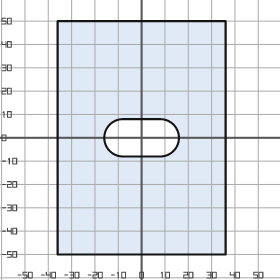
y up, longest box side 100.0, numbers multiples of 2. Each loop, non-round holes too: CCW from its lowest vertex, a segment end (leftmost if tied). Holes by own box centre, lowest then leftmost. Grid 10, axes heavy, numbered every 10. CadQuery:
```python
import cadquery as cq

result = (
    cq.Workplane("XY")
    .moveTo(-36.0, -50.0)
    .lineTo(36.0, -50.0)
    .lineTo(36.0, 50.0)
    .lineTo(-36.0, 50.0)
    .close()
    .moveTo(-8.0, -8.0)
    .lineTo(8.0, -8.0)
    .threePointArc((16.0, 0.0), (8.0, 8.0))
    .lineTo(-8.0, 8.0)
    .threePointArc((-16.0, 0.0), (-8.0, -8.0))
    .close()
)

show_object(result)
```